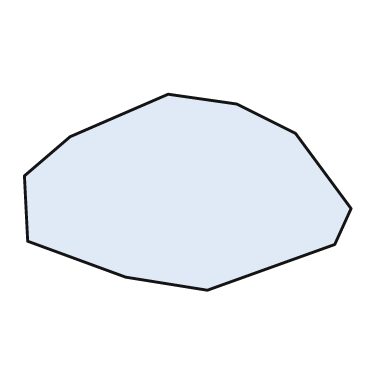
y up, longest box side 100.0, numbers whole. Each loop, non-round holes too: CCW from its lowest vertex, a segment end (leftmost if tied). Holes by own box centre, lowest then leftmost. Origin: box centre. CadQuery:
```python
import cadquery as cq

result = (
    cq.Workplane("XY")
    .moveTo(6.0, -30.0)
    .lineTo(45.0, -16.0)
    .lineTo(50.0, -5.0)
    .lineTo(33.0, 18.0)
    .lineTo(15.0, 27.0)
    .lineTo(-6.0, 30.0)
    .lineTo(-36.0, 17.0)
    .lineTo(-50.0, 5.0)
    .lineTo(-49.0, -15.0)
    .lineTo(-19.0, -26.0)
    .close()
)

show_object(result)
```